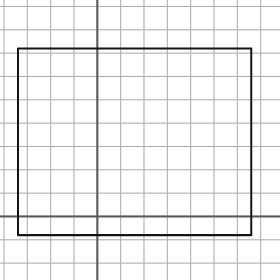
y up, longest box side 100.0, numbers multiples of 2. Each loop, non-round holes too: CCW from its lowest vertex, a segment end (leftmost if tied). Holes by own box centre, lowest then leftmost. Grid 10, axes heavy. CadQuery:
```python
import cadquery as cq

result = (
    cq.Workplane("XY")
    .moveTo(-34.0, -8.0)
    .lineTo(66.0, -8.0)
    .lineTo(66.0, 72.0)
    .lineTo(-34.0, 72.0)
    .close()
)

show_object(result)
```